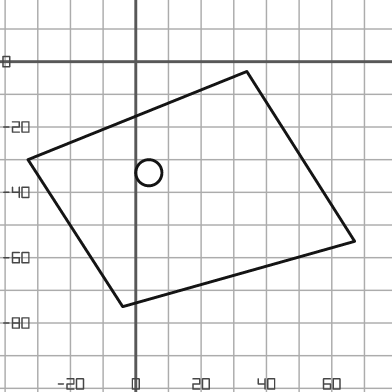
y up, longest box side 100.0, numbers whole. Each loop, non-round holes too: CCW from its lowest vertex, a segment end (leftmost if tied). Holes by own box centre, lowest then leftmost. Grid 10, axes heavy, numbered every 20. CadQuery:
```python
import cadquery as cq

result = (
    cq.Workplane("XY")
    .moveTo(-4.0, -75.0)
    .lineTo(67.0, -55.0)
    .lineTo(34.0, -3.0)
    .lineTo(-33.0, -30.0)
    .close()
    .moveTo(4.0, -34.0)
    .circle(4.0)
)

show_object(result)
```